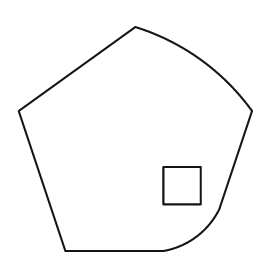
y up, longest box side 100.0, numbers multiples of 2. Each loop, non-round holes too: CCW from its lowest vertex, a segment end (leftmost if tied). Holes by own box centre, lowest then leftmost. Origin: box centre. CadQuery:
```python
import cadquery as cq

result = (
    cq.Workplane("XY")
    .moveTo(-30.0, -48.0)
    .lineTo(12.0, -48.0)
    .threePointArc((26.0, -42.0), (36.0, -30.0))
    .lineTo(50.0, 12.0)
    .threePointArc((28.0, 34.0), (0.0, 48.0))
    .lineTo(-50.0, 12.0)
    .close()
    .moveTo(12.0, -28.0)
    .lineTo(28.0, -28.0)
    .lineTo(28.0, -12.0)
    .lineTo(12.0, -12.0)
    .close()
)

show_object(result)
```